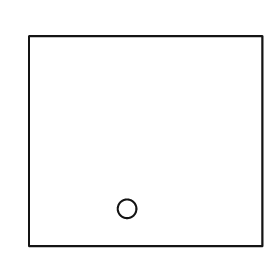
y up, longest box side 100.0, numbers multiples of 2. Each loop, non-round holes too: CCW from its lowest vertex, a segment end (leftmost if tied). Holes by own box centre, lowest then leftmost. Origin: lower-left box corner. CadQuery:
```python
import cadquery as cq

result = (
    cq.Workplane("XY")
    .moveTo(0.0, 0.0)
    .lineTo(100.0, 0.0)
    .lineTo(100.0, 90.0)
    .lineTo(0.0, 90.0)
    .close()
    .moveTo(42.0, 16.0)
    .circle(4.0)
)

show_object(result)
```